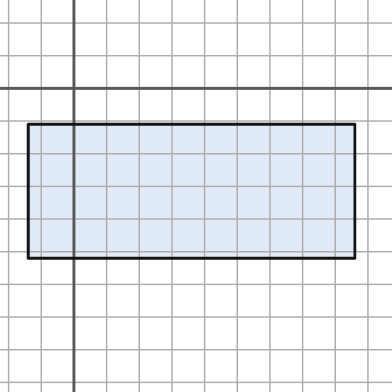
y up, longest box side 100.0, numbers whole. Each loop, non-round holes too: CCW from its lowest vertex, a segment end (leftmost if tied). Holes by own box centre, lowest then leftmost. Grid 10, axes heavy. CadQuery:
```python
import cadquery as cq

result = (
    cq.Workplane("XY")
    .moveTo(-14.0, -52.0)
    .lineTo(86.0, -52.0)
    .lineTo(86.0, -11.0)
    .lineTo(-14.0, -11.0)
    .close()
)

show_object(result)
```